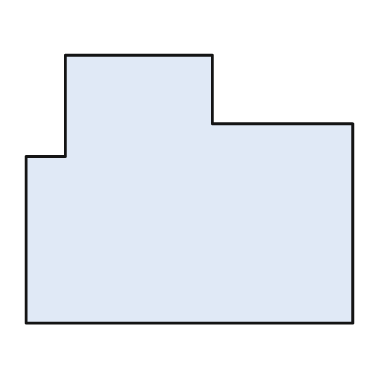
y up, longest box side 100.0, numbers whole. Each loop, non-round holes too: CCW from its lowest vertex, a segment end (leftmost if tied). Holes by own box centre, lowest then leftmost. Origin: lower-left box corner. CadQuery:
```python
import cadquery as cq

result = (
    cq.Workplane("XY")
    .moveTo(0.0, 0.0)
    .lineTo(100.0, 0.0)
    .lineTo(100.0, 61.0)
    .lineTo(57.0, 61.0)
    .lineTo(57.0, 82.0)
    .lineTo(12.0, 82.0)
    .lineTo(12.0, 51.0)
    .lineTo(0.0, 51.0)
    .close()
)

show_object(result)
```